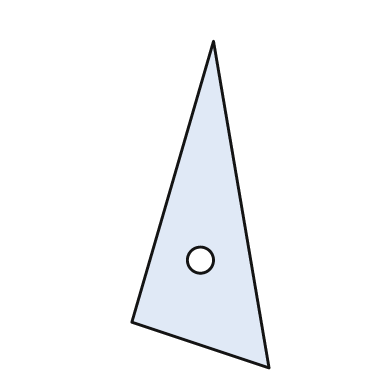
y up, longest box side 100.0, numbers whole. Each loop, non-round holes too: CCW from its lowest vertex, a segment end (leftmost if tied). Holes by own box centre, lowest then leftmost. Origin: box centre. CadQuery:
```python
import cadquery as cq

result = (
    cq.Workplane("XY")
    .moveTo(21.0, -50.0)
    .lineTo(4.0, 50.0)
    .lineTo(-21.0, -36.0)
    .close()
    .moveTo(0.0, -17.0)
    .circle(4.0)
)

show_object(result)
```